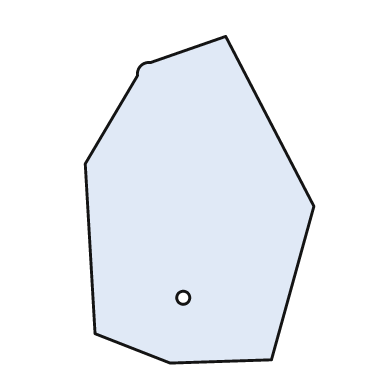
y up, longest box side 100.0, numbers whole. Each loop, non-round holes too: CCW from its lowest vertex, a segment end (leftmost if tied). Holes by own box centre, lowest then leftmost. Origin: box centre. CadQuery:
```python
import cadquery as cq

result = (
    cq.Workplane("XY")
    .moveTo(-9.0, -50.0)
    .lineTo(22.0, -49.0)
    .lineTo(35.0, -2.0)
    .lineTo(8.0, 50.0)
    .lineTo(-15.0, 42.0)
    .threePointArc((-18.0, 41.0), (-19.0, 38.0))
    .lineTo(-35.0, 11.0)
    .lineTo(-32.0, -41.0)
    .close()
    .moveTo(-5.0, -30.0)
    .circle(2.0)
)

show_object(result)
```